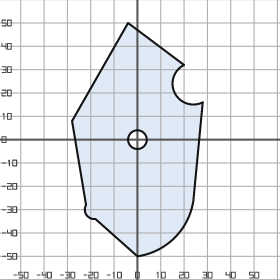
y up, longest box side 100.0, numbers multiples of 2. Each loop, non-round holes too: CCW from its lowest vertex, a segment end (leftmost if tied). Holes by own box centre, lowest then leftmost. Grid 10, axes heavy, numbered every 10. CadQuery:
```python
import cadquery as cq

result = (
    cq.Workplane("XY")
    .moveTo(0.0, -50.0)
    .threePointArc((16.0, -42.0), (24.0, -26.0))
    .lineTo(28.0, 16.0)
    .threePointArc((16.0, 20.0), (20.0, 32.0))
    .lineTo(-4.0, 50.0)
    .lineTo(-28.0, 8.0)
    .lineTo(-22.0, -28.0)
    .threePointArc((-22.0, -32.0), (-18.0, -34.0))
    .close()
    .moveTo(0.0, 0.0)
    .circle(4.0)
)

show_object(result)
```